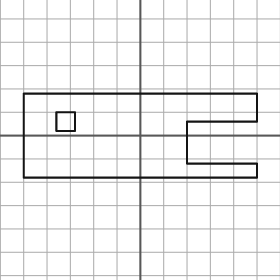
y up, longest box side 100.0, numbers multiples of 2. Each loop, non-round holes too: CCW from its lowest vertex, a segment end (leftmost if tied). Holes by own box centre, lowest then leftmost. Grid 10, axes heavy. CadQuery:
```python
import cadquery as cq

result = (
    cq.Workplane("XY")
    .moveTo(-50.0, -18.0)
    .lineTo(50.0, -18.0)
    .lineTo(50.0, -12.0)
    .lineTo(20.0, -12.0)
    .lineTo(20.0, 6.0)
    .lineTo(50.0, 6.0)
    .lineTo(50.0, 18.0)
    .lineTo(-50.0, 18.0)
    .close()
    .moveTo(-36.0, 2.0)
    .lineTo(-28.0, 2.0)
    .lineTo(-28.0, 10.0)
    .lineTo(-36.0, 10.0)
    .close()
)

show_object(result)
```